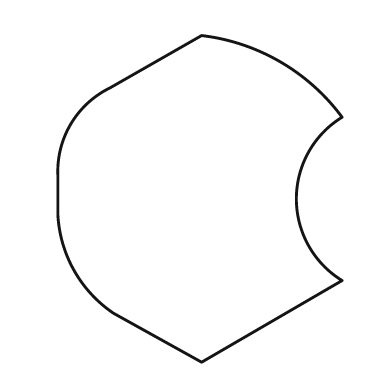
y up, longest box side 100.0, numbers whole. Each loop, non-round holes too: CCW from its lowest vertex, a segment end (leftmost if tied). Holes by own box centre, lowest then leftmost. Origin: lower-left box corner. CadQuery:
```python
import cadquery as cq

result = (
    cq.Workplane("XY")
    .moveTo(44.0, 0.0)
    .lineTo(87.0, 25.0)
    .threePointArc((73.0, 50.0), (87.0, 75.0))
    .threePointArc((68.0, 92.0), (44.0, 100.0))
    .lineTo(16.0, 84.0)
    .threePointArc((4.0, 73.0), (0.0, 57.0))
    .lineTo(0.0, 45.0)
    .threePointArc((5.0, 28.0), (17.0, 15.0))
    .close()
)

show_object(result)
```